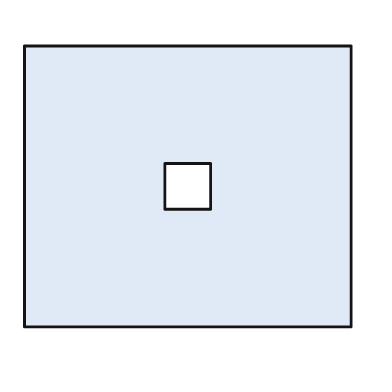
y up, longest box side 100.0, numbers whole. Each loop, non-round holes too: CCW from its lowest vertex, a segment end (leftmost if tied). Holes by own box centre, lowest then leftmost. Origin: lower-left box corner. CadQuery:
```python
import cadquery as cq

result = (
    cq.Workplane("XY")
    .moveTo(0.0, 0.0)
    .lineTo(100.0, 0.0)
    .lineTo(100.0, 86.0)
    .lineTo(0.0, 86.0)
    .close()
    .moveTo(43.0, 36.0)
    .lineTo(57.0, 36.0)
    .lineTo(57.0, 50.0)
    .lineTo(43.0, 50.0)
    .close()
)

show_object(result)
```